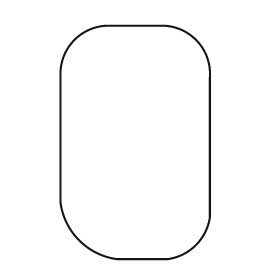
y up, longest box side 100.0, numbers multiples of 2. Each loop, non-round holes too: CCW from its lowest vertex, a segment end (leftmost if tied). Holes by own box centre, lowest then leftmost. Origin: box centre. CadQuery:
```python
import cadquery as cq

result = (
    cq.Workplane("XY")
    .moveTo(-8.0, -50.0)
    .lineTo(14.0, -50.0)
    .threePointArc((26.0, -44.0), (32.0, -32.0))
    .lineTo(32.0, 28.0)
    .threePointArc((26.0, 44.0), (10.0, 50.0))
    .lineTo(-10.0, 50.0)
    .threePointArc((-26.0, 44.0), (-32.0, 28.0))
    .lineTo(-32.0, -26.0)
    .threePointArc((-24.0, -42.0), (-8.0, -50.0))
    .close()
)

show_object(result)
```